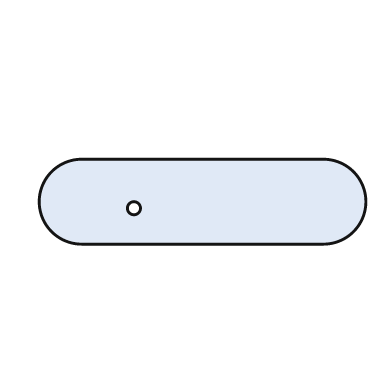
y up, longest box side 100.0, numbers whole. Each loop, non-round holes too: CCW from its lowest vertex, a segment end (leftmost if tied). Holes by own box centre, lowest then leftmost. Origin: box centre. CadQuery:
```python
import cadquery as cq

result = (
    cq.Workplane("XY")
    .moveTo(-37.0, -13.0)
    .lineTo(37.0, -13.0)
    .threePointArc((50.0, 0.0), (37.0, 13.0))
    .lineTo(-37.0, 13.0)
    .threePointArc((-50.0, 0.0), (-37.0, -13.0))
    .close()
    .moveTo(-21.0, -2.0)
    .circle(2.0)
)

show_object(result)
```